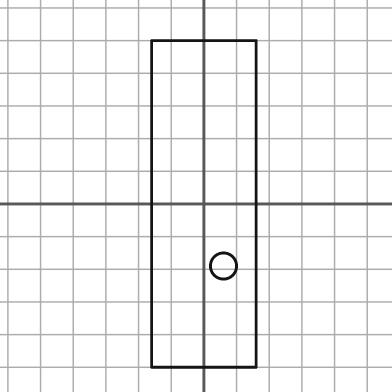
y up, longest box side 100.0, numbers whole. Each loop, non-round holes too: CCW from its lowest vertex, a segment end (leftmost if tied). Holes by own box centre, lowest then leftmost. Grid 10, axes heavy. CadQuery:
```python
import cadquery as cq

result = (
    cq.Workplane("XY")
    .moveTo(-16.0, -50.0)
    .lineTo(16.0, -50.0)
    .lineTo(16.0, 50.0)
    .lineTo(-16.0, 50.0)
    .close()
    .moveTo(6.0, -19.0)
    .circle(4.0)
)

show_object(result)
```